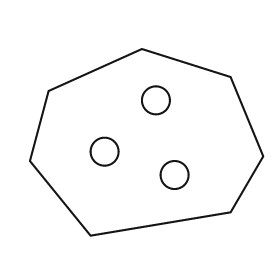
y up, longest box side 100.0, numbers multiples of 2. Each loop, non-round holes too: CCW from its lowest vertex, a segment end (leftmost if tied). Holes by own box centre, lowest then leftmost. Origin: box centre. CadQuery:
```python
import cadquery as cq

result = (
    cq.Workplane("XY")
    .moveTo(-24.0, -40.0)
    .lineTo(36.0, -30.0)
    .lineTo(50.0, -6.0)
    .lineTo(36.0, 28.0)
    .lineTo(-2.0, 40.0)
    .lineTo(-42.0, 22.0)
    .lineTo(-50.0, -8.0)
    .close()
    .moveTo(12.0, -14.0)
    .circle(6.0)
    .moveTo(-18.0, -4.0)
    .circle(6.0)
    .moveTo(4.0, 18.0)
    .circle(6.0)
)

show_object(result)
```